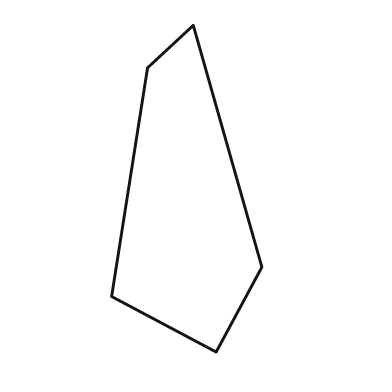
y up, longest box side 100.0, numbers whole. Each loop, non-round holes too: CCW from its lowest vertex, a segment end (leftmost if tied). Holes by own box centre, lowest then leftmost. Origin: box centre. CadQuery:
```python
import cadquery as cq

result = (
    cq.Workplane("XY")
    .moveTo(9.0, -50.0)
    .lineTo(23.0, -24.0)
    .lineTo(2.0, 50.0)
    .lineTo(-12.0, 37.0)
    .lineTo(-23.0, -33.0)
    .close()
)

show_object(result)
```